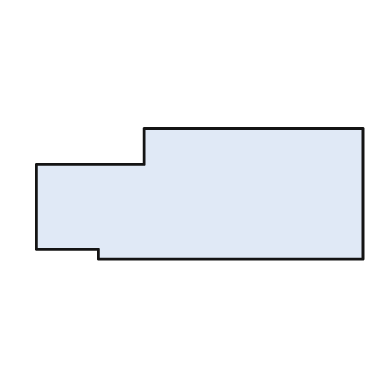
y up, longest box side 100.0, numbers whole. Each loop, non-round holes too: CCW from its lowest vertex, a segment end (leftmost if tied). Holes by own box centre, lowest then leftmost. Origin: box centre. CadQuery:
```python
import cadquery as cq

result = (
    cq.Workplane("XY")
    .moveTo(-31.0, -20.0)
    .lineTo(50.0, -20.0)
    .lineTo(50.0, 20.0)
    .lineTo(-17.0, 20.0)
    .lineTo(-17.0, 9.0)
    .lineTo(-50.0, 9.0)
    .lineTo(-50.0, -17.0)
    .lineTo(-31.0, -17.0)
    .close()
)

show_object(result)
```